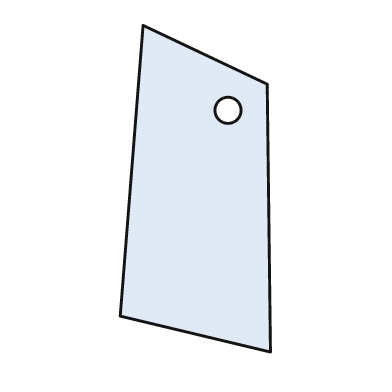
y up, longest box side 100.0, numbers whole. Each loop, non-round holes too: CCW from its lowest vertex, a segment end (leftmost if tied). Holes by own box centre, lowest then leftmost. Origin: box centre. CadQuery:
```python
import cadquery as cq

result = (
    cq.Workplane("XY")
    .moveTo(23.0, -50.0)
    .lineTo(22.0, 32.0)
    .lineTo(-16.0, 50.0)
    .lineTo(-23.0, -39.0)
    .close()
    .moveTo(10.0, 24.0)
    .circle(4.0)
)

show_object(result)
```